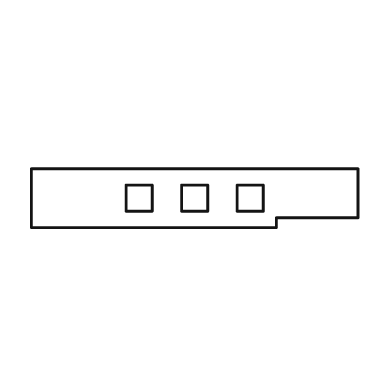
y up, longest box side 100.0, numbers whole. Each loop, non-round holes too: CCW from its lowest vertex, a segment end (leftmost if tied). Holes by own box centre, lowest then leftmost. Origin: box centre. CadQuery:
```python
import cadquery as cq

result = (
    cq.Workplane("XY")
    .moveTo(-50.0, -9.0)
    .lineTo(25.0, -9.0)
    .lineTo(25.0, -6.0)
    .lineTo(50.0, -6.0)
    .lineTo(50.0, 9.0)
    .lineTo(-50.0, 9.0)
    .close()
    .moveTo(-21.0, -4.0)
    .lineTo(-13.0, -4.0)
    .lineTo(-13.0, 4.0)
    .lineTo(-21.0, 4.0)
    .close()
    .moveTo(-4.0, -4.0)
    .lineTo(4.0, -4.0)
    .lineTo(4.0, 4.0)
    .lineTo(-4.0, 4.0)
    .close()
    .moveTo(13.0, -4.0)
    .lineTo(21.0, -4.0)
    .lineTo(21.0, 4.0)
    .lineTo(13.0, 4.0)
    .close()
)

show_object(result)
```